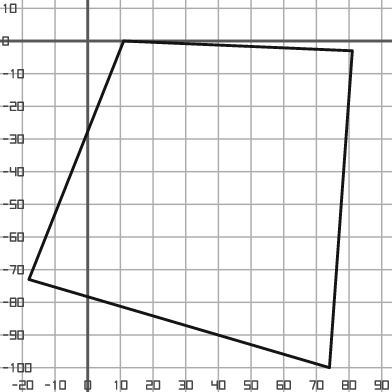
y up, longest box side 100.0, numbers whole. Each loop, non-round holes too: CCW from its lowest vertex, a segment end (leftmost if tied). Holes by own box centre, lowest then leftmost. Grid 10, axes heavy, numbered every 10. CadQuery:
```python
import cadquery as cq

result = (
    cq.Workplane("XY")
    .moveTo(74.0, -100.0)
    .lineTo(81.0, -3.0)
    .lineTo(11.0, 0.0)
    .lineTo(-18.0, -73.0)
    .close()
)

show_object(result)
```